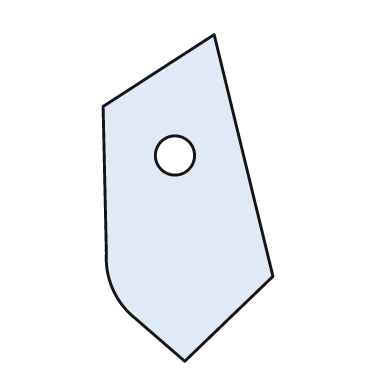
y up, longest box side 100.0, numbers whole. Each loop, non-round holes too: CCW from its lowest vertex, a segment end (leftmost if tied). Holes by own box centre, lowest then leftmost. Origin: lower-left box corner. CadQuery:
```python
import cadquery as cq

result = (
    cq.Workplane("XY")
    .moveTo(25.0, 0.0)
    .lineTo(52.0, 26.0)
    .lineTo(34.0, 100.0)
    .lineTo(0.0, 78.0)
    .lineTo(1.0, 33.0)
    .threePointArc((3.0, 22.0), (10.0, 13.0))
    .close()
    .moveTo(22.0, 63.0)
    .circle(6.0)
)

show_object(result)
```